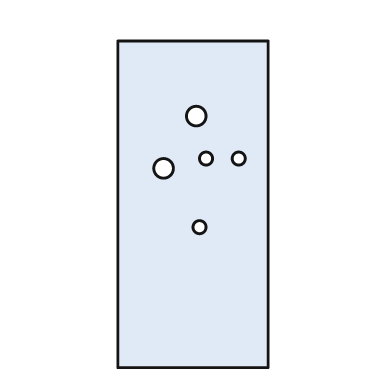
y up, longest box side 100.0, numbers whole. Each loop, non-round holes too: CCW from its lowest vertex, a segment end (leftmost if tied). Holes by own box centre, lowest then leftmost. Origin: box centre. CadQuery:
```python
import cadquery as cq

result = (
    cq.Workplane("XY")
    .moveTo(-23.0, -50.0)
    .lineTo(23.0, -50.0)
    .lineTo(23.0, 50.0)
    .lineTo(-23.0, 50.0)
    .close()
    .moveTo(2.0, -7.0)
    .circle(2.0)
    .moveTo(-9.0, 11.0)
    .circle(3.0)
    .moveTo(4.0, 14.0)
    .circle(2.0)
    .moveTo(14.0, 14.0)
    .circle(2.0)
    .moveTo(1.0, 27.0)
    .circle(3.0)
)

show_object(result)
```